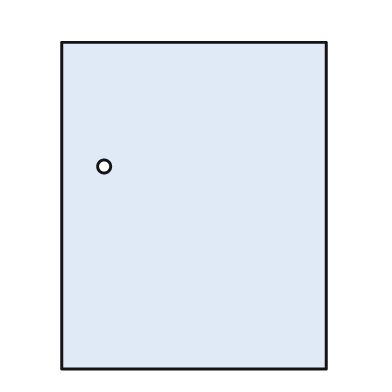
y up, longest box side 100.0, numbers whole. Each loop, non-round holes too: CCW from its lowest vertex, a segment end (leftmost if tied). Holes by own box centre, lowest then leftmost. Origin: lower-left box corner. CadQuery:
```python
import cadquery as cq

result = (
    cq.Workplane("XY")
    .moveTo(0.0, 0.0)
    .lineTo(81.0, 0.0)
    .lineTo(81.0, 100.0)
    .lineTo(0.0, 100.0)
    .close()
    .moveTo(13.0, 62.0)
    .circle(2.0)
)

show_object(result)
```